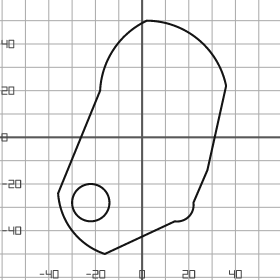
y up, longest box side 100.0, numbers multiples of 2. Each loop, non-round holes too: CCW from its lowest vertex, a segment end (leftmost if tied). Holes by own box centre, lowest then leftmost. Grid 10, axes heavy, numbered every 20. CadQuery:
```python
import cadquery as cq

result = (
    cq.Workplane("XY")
    .moveTo(-16.0, -50.0)
    .lineTo(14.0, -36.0)
    .threePointArc((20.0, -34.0), (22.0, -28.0))
    .lineTo(28.0, -14.0)
    .lineTo(36.0, 22.0)
    .threePointArc((24.0, 42.0), (2.0, 50.0))
    .threePointArc((-12.0, 38.0), (-18.0, 20.0))
    .lineTo(-36.0, -24.0)
    .threePointArc((-30.0, -40.0), (-16.0, -50.0))
    .close()
    .moveTo(-22.0, -28.0)
    .circle(8.0)
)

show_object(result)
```